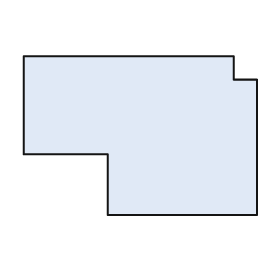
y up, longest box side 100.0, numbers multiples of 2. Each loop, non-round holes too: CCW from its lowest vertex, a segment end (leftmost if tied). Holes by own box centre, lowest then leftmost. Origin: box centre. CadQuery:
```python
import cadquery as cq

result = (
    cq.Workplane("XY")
    .moveTo(-14.0, -34.0)
    .lineTo(50.0, -34.0)
    .lineTo(50.0, 24.0)
    .lineTo(40.0, 24.0)
    .lineTo(40.0, 34.0)
    .lineTo(-50.0, 34.0)
    .lineTo(-50.0, -8.0)
    .lineTo(-14.0, -8.0)
    .close()
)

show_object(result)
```